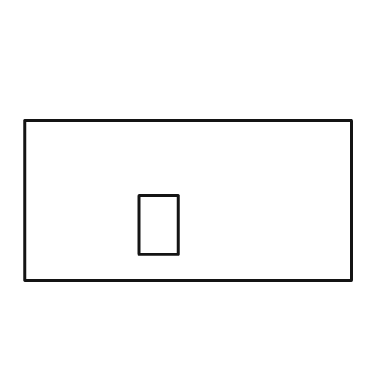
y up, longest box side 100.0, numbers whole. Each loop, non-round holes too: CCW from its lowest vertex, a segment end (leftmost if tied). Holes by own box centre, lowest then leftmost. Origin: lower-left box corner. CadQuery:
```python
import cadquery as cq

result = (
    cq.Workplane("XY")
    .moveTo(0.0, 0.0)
    .lineTo(100.0, 0.0)
    .lineTo(100.0, 49.0)
    .lineTo(0.0, 49.0)
    .close()
    .moveTo(35.0, 8.0)
    .lineTo(47.0, 8.0)
    .lineTo(47.0, 26.0)
    .lineTo(35.0, 26.0)
    .close()
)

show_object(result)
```